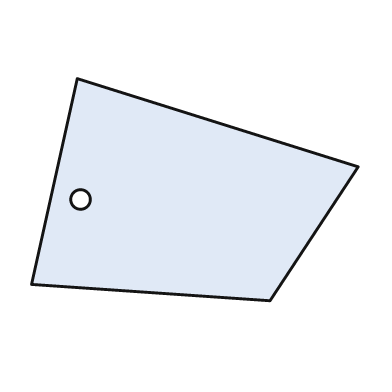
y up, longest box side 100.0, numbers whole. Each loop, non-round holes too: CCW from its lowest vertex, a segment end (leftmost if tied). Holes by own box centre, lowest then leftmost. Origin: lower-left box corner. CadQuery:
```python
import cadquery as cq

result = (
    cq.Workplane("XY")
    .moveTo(73.0, 0.0)
    .lineTo(100.0, 41.0)
    .lineTo(14.0, 68.0)
    .lineTo(0.0, 5.0)
    .close()
    .moveTo(15.0, 31.0)
    .circle(3.0)
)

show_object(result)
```